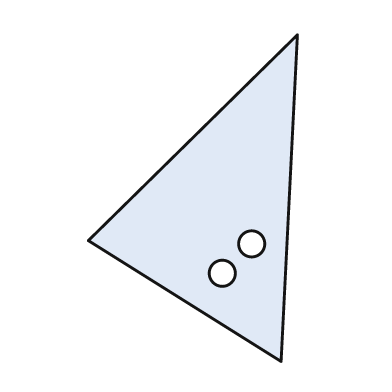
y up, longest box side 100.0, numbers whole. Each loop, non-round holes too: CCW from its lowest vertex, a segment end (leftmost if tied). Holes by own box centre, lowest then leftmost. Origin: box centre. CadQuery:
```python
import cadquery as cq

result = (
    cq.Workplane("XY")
    .moveTo(27.0, -50.0)
    .lineTo(32.0, 50.0)
    .lineTo(-32.0, -13.0)
    .close()
    .moveTo(9.0, -23.0)
    .circle(4.0)
    .moveTo(18.0, -14.0)
    .circle(4.0)
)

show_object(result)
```